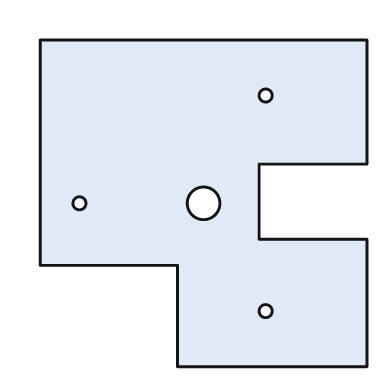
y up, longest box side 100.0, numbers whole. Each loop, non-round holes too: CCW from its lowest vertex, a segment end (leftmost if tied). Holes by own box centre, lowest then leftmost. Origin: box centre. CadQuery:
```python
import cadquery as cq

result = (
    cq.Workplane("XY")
    .moveTo(-8.0, -50.0)
    .lineTo(50.0, -50.0)
    .lineTo(50.0, -11.0)
    .lineTo(17.0, -11.0)
    .lineTo(17.0, 12.0)
    .lineTo(50.0, 12.0)
    .lineTo(50.0, 50.0)
    .lineTo(-50.0, 50.0)
    .lineTo(-50.0, -19.0)
    .lineTo(-8.0, -19.0)
    .close()
    .moveTo(19.0, -33.0)
    .circle(2.0)
    .moveTo(-38.0, 0.0)
    .circle(2.0)
    .moveTo(0.0, 0.0)
    .circle(5.0)
    .moveTo(19.0, 33.0)
    .circle(2.0)
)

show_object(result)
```